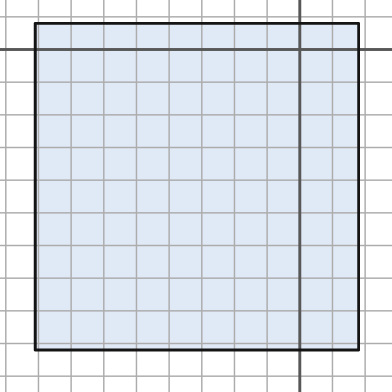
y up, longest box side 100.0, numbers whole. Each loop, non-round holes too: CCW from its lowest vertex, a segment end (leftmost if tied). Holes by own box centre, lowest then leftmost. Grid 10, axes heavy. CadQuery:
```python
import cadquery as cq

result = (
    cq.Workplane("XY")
    .moveTo(-81.0, -92.0)
    .lineTo(18.0, -92.0)
    .lineTo(18.0, 8.0)
    .lineTo(-81.0, 8.0)
    .close()
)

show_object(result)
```